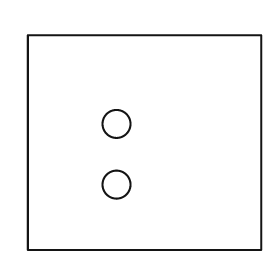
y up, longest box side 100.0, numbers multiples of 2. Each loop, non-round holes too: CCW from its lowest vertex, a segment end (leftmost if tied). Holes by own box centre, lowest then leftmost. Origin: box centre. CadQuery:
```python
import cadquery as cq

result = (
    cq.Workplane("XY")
    .moveTo(-50.0, -46.0)
    .lineTo(50.0, -46.0)
    .lineTo(50.0, 46.0)
    .lineTo(-50.0, 46.0)
    .close()
    .moveTo(-12.0, -18.0)
    .circle(6.0)
    .moveTo(-12.0, 8.0)
    .circle(6.0)
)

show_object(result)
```